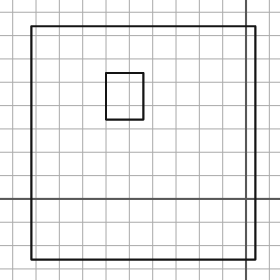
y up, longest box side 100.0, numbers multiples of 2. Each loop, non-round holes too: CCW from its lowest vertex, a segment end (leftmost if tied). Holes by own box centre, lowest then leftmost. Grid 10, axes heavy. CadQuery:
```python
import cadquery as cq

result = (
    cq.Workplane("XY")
    .moveTo(-92.0, -26.0)
    .lineTo(4.0, -26.0)
    .lineTo(4.0, 74.0)
    .lineTo(-92.0, 74.0)
    .close()
    .moveTo(-60.0, 34.0)
    .lineTo(-44.0, 34.0)
    .lineTo(-44.0, 54.0)
    .lineTo(-60.0, 54.0)
    .close()
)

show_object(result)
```